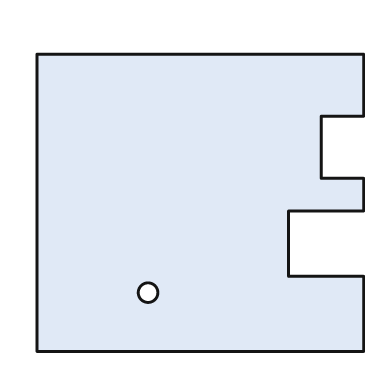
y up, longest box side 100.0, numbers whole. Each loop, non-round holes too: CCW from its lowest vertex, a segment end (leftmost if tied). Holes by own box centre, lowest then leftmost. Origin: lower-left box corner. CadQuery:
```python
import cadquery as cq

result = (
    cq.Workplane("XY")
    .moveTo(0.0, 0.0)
    .lineTo(100.0, 0.0)
    .lineTo(100.0, 23.0)
    .lineTo(77.0, 23.0)
    .lineTo(77.0, 43.0)
    .lineTo(100.0, 43.0)
    .lineTo(100.0, 53.0)
    .lineTo(87.0, 53.0)
    .lineTo(87.0, 72.0)
    .lineTo(100.0, 72.0)
    .lineTo(100.0, 91.0)
    .lineTo(0.0, 91.0)
    .close()
    .moveTo(34.0, 18.0)
    .circle(3.0)
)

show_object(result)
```